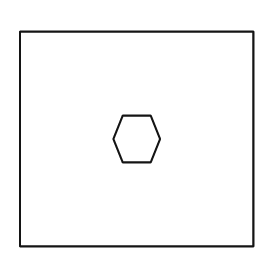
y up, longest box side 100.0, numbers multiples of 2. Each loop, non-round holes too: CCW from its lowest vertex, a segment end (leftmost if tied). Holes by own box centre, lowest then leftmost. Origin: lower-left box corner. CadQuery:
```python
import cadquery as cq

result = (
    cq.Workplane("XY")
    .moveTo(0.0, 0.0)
    .lineTo(100.0, 0.0)
    .lineTo(100.0, 92.0)
    .lineTo(0.0, 92.0)
    .close()
    .moveTo(44.0, 36.0)
    .lineTo(56.0, 36.0)
    .lineTo(60.0, 46.0)
    .lineTo(56.0, 56.0)
    .lineTo(44.0, 56.0)
    .lineTo(40.0, 46.0)
    .close()
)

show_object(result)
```